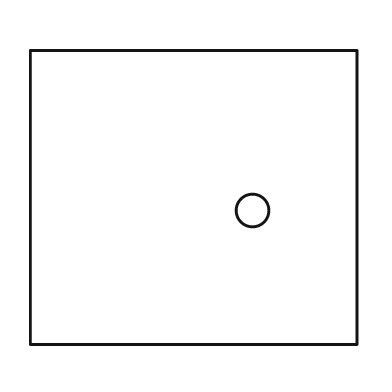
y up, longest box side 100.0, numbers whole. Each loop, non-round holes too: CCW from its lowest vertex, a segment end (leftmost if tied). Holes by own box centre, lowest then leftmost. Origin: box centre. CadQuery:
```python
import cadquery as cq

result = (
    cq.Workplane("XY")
    .moveTo(-50.0, -45.0)
    .lineTo(50.0, -45.0)
    .lineTo(50.0, 45.0)
    .lineTo(-50.0, 45.0)
    .close()
    .moveTo(18.0, -4.0)
    .circle(5.0)
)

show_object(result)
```